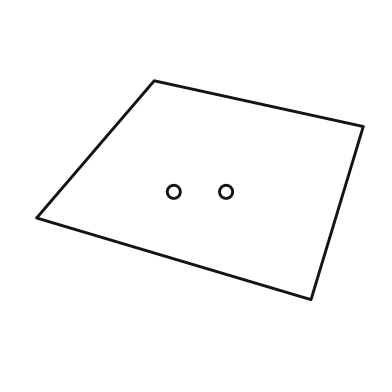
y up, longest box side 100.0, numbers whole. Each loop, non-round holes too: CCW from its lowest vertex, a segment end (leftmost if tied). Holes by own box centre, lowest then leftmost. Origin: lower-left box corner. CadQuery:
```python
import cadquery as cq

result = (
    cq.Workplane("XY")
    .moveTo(84.0, 0.0)
    .lineTo(100.0, 53.0)
    .lineTo(36.0, 67.0)
    .lineTo(0.0, 25.0)
    .close()
    .moveTo(42.0, 33.0)
    .circle(2.0)
    .moveTo(58.0, 33.0)
    .circle(2.0)
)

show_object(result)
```